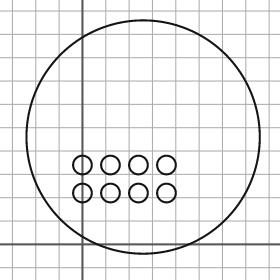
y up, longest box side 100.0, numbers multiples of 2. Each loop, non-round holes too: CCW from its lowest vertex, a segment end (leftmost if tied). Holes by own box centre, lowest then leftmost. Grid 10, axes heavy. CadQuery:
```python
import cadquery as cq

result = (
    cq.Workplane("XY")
    .moveTo(26.0, 46.0)
    .circle(50.0)
    .moveTo(0.0, 22.0)
    .circle(4.0)
    .moveTo(12.0, 22.0)
    .circle(4.0)
    .moveTo(24.0, 22.0)
    .circle(4.0)
    .moveTo(36.0, 22.0)
    .circle(4.0)
    .moveTo(0.0, 34.0)
    .circle(4.0)
    .moveTo(12.0, 34.0)
    .circle(4.0)
    .moveTo(24.0, 34.0)
    .circle(4.0)
    .moveTo(36.0, 34.0)
    .circle(4.0)
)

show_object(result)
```